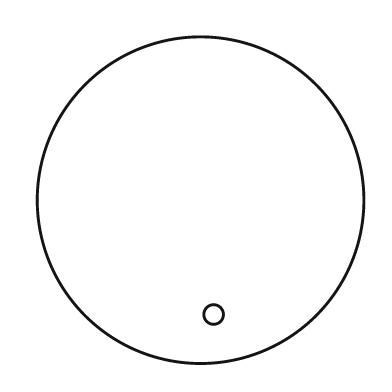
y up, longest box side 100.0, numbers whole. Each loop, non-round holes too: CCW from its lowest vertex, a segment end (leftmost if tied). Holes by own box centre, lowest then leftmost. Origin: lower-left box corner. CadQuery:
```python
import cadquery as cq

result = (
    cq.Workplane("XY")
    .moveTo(50.0, 50.0)
    .circle(50.0)
    .moveTo(54.0, 15.0)
    .circle(3.0)
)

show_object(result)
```